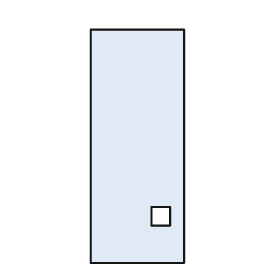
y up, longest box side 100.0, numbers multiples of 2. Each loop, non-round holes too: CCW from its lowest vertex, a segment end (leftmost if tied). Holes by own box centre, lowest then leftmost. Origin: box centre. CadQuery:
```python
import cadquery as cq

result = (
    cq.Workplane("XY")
    .moveTo(-20.0, -50.0)
    .lineTo(20.0, -50.0)
    .lineTo(20.0, 50.0)
    .lineTo(-20.0, 50.0)
    .close()
    .moveTo(6.0, -34.0)
    .lineTo(14.0, -34.0)
    .lineTo(14.0, -26.0)
    .lineTo(6.0, -26.0)
    .close()
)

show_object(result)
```